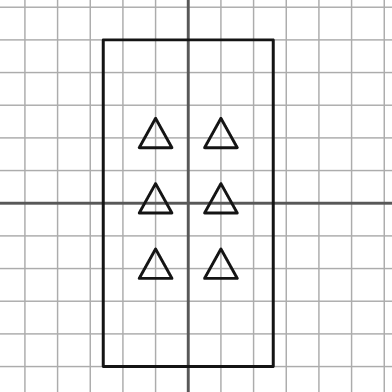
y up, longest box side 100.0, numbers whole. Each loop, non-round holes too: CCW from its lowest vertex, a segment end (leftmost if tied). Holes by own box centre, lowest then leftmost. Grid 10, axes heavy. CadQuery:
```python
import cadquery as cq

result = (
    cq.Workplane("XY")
    .moveTo(-26.0, -50.0)
    .lineTo(26.0, -50.0)
    .lineTo(26.0, 50.0)
    .lineTo(-26.0, 50.0)
    .close()
    .moveTo(-15.0, -23.0)
    .lineTo(-5.0, -23.0)
    .lineTo(-10.0, -14.0)
    .close()
    .moveTo(5.0, -23.0)
    .lineTo(15.0, -23.0)
    .lineTo(10.0, -14.0)
    .close()
    .moveTo(-15.0, -3.0)
    .lineTo(-5.0, -3.0)
    .lineTo(-10.0, 6.0)
    .close()
    .moveTo(5.0, -3.0)
    .lineTo(15.0, -3.0)
    .lineTo(10.0, 6.0)
    .close()
    .moveTo(-15.0, 17.0)
    .lineTo(-5.0, 17.0)
    .lineTo(-10.0, 26.0)
    .close()
    .moveTo(5.0, 17.0)
    .lineTo(15.0, 17.0)
    .lineTo(10.0, 26.0)
    .close()
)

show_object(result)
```